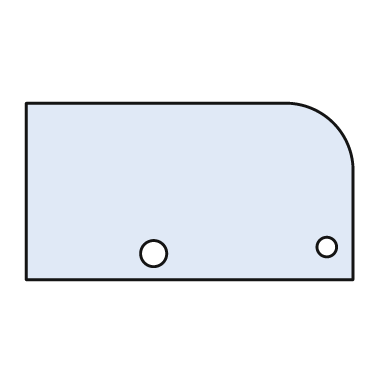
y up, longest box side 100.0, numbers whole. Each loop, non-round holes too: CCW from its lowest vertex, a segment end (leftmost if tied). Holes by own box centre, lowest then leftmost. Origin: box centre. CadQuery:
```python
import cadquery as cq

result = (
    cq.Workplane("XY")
    .moveTo(-50.0, -27.0)
    .lineTo(50.0, -27.0)
    .lineTo(50.0, 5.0)
    .threePointArc((44.0, 21.0), (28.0, 27.0))
    .lineTo(-50.0, 27.0)
    .close()
    .moveTo(-11.0, -19.0)
    .circle(4.0)
    .moveTo(42.0, -17.0)
    .circle(3.0)
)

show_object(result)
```